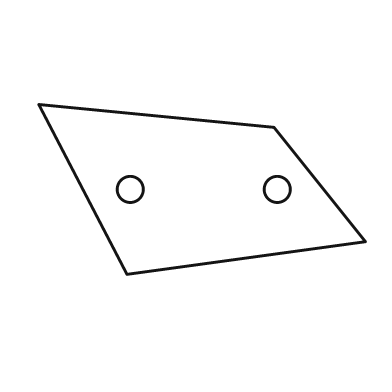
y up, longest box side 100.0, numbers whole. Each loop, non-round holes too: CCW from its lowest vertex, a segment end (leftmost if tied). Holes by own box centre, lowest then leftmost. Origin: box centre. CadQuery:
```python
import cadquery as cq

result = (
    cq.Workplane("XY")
    .moveTo(-23.0, -26.0)
    .lineTo(50.0, -16.0)
    .lineTo(22.0, 19.0)
    .lineTo(-50.0, 26.0)
    .close()
    .moveTo(-22.0, 0.0)
    .circle(4.0)
    .moveTo(23.0, 0.0)
    .circle(4.0)
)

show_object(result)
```